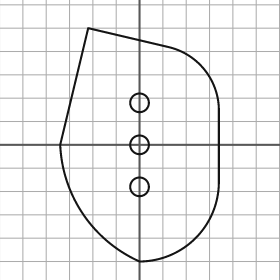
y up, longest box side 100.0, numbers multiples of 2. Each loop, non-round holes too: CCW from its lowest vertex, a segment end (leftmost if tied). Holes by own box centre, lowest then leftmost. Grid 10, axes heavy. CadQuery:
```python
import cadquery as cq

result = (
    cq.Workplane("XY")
    .moveTo(0.0, -50.0)
    .threePointArc((24.0, -40.0), (34.0, -16.0))
    .lineTo(34.0, 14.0)
    .threePointArc((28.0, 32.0), (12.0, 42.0))
    .lineTo(-22.0, 50.0)
    .lineTo(-34.0, 0.0)
    .threePointArc((-24.0, -30.0), (0.0, -50.0))
    .close()
    .moveTo(0.0, -18.0)
    .circle(4.0)
    .moveTo(0.0, 0.0)
    .circle(4.0)
    .moveTo(0.0, 18.0)
    .circle(4.0)
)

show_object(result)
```